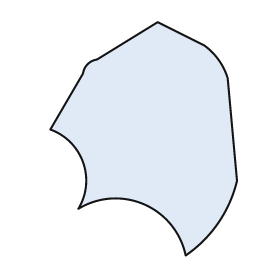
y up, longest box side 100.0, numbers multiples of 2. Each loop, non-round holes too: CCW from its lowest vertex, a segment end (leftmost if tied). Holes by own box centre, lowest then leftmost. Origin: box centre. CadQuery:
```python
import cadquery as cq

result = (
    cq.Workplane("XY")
    .moveTo(18.0, -50.0)
    .threePointArc((32.0, -36.0), (40.0, -18.0))
    .lineTo(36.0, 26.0)
    .threePointArc((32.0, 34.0), (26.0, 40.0))
    .lineTo(6.0, 50.0)
    .lineTo(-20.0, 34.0)
    .threePointArc((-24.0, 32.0), (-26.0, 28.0))
    .lineTo(-40.0, 4.0)
    .threePointArc((-26.0, -10.0), (-28.0, -30.0))
    .threePointArc((0.0, -28.0), (18.0, -50.0))
    .close()
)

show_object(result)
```